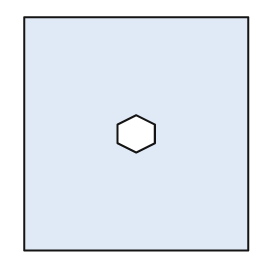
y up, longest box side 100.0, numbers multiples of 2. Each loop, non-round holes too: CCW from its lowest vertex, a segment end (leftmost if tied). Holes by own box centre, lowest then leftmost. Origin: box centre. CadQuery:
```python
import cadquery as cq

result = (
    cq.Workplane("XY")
    .moveTo(-48.0, -50.0)
    .lineTo(48.0, -50.0)
    .lineTo(48.0, 50.0)
    .lineTo(-48.0, 50.0)
    .close()
    .moveTo(0.0, -8.0)
    .lineTo(8.0, -4.0)
    .lineTo(8.0, 4.0)
    .lineTo(0.0, 8.0)
    .lineTo(-8.0, 4.0)
    .lineTo(-8.0, -4.0)
    .close()
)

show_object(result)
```